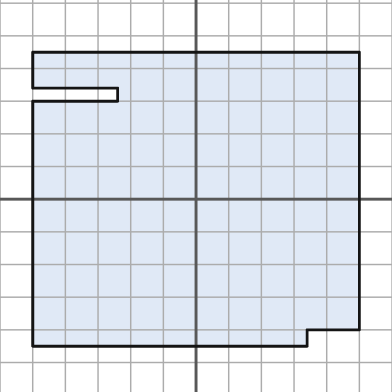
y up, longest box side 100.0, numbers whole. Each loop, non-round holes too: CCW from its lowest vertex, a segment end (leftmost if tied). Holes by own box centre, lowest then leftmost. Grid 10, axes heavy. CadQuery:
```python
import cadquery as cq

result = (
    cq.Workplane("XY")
    .moveTo(-50.0, -45.0)
    .lineTo(34.0, -45.0)
    .lineTo(34.0, -40.0)
    .lineTo(50.0, -40.0)
    .lineTo(50.0, 45.0)
    .lineTo(-50.0, 45.0)
    .lineTo(-50.0, 34.0)
    .lineTo(-24.0, 34.0)
    .lineTo(-24.0, 30.0)
    .lineTo(-50.0, 30.0)
    .close()
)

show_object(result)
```